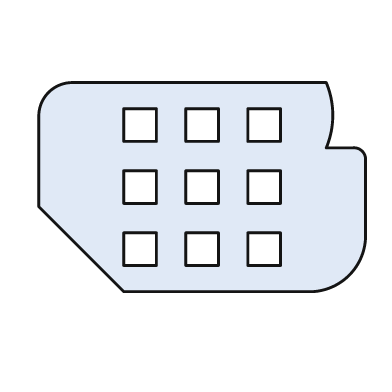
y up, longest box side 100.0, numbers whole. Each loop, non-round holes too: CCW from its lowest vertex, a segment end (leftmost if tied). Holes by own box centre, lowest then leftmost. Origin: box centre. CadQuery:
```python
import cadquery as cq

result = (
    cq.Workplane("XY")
    .moveTo(-24.0, -32.0)
    .lineTo(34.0, -32.0)
    .threePointArc((45.0, -27.0), (50.0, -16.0))
    .lineTo(50.0, 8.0)
    .threePointArc((49.0, 11.0), (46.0, 12.0))
    .lineTo(38.0, 12.0)
    .threePointArc((40.0, 22.0), (38.0, 32.0))
    .lineTo(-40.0, 32.0)
    .threePointArc((-47.0, 29.0), (-50.0, 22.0))
    .lineTo(-50.0, -6.0)
    .close()
    .moveTo(-24.0, -24.0)
    .lineTo(-14.0, -24.0)
    .lineTo(-14.0, -14.0)
    .lineTo(-24.0, -14.0)
    .close()
    .moveTo(-5.0, -24.0)
    .lineTo(5.0, -24.0)
    .lineTo(5.0, -14.0)
    .lineTo(-5.0, -14.0)
    .close()
    .moveTo(14.0, -24.0)
    .lineTo(24.0, -24.0)
    .lineTo(24.0, -14.0)
    .lineTo(14.0, -14.0)
    .close()
    .moveTo(-24.0, -5.0)
    .lineTo(-14.0, -5.0)
    .lineTo(-14.0, 5.0)
    .lineTo(-24.0, 5.0)
    .close()
    .moveTo(-5.0, -5.0)
    .lineTo(5.0, -5.0)
    .lineTo(5.0, 5.0)
    .lineTo(-5.0, 5.0)
    .close()
    .moveTo(14.0, -5.0)
    .lineTo(24.0, -5.0)
    .lineTo(24.0, 5.0)
    .lineTo(14.0, 5.0)
    .close()
    .moveTo(-24.0, 14.0)
    .lineTo(-14.0, 14.0)
    .lineTo(-14.0, 24.0)
    .lineTo(-24.0, 24.0)
    .close()
    .moveTo(-5.0, 14.0)
    .lineTo(5.0, 14.0)
    .lineTo(5.0, 24.0)
    .lineTo(-5.0, 24.0)
    .close()
    .moveTo(14.0, 14.0)
    .lineTo(24.0, 14.0)
    .lineTo(24.0, 24.0)
    .lineTo(14.0, 24.0)
    .close()
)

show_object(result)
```